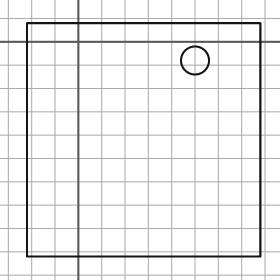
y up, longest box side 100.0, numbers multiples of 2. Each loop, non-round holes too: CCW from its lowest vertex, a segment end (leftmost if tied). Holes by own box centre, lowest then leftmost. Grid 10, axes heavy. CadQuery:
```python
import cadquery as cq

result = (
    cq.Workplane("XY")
    .moveTo(-22.0, -92.0)
    .lineTo(78.0, -92.0)
    .lineTo(78.0, 8.0)
    .lineTo(-22.0, 8.0)
    .close()
    .moveTo(50.0, -8.0)
    .circle(6.0)
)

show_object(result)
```